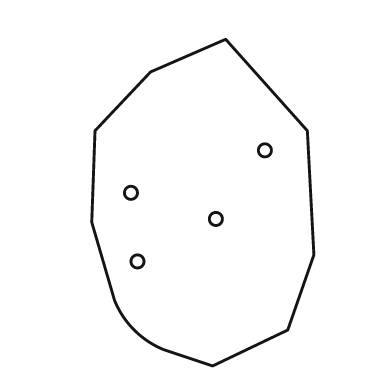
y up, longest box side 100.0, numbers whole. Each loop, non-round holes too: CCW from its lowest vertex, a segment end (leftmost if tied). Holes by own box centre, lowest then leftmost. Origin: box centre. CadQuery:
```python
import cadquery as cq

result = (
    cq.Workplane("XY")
    .moveTo(3.0, -50.0)
    .lineTo(26.0, -39.0)
    .lineTo(34.0, -16.0)
    .lineTo(32.0, 22.0)
    .lineTo(7.0, 50.0)
    .lineTo(-16.0, 40.0)
    .lineTo(-33.0, 22.0)
    .lineTo(-34.0, -6.0)
    .lineTo(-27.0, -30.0)
    .threePointArc((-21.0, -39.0), (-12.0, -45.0))
    .close()
    .moveTo(-20.0, -18.0)
    .circle(2.0)
    .moveTo(4.0, -5.0)
    .circle(2.0)
    .moveTo(-22.0, 3.0)
    .circle(2.0)
    .moveTo(19.0, 16.0)
    .circle(2.0)
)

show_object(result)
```